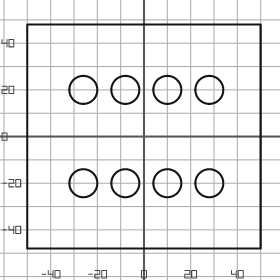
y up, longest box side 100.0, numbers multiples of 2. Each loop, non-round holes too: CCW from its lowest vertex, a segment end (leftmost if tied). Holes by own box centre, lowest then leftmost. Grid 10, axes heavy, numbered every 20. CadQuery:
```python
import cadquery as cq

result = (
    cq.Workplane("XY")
    .moveTo(-50.0, -48.0)
    .lineTo(50.0, -48.0)
    .lineTo(50.0, 48.0)
    .lineTo(-50.0, 48.0)
    .close()
    .moveTo(-26.0, -20.0)
    .circle(6.0)
    .moveTo(-8.0, -20.0)
    .circle(6.0)
    .moveTo(10.0, -20.0)
    .circle(6.0)
    .moveTo(28.0, -20.0)
    .circle(6.0)
    .moveTo(-26.0, 20.0)
    .circle(6.0)
    .moveTo(-8.0, 20.0)
    .circle(6.0)
    .moveTo(10.0, 20.0)
    .circle(6.0)
    .moveTo(28.0, 20.0)
    .circle(6.0)
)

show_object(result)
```